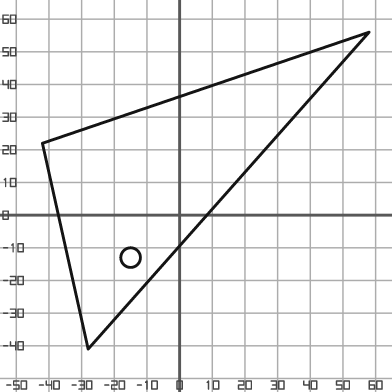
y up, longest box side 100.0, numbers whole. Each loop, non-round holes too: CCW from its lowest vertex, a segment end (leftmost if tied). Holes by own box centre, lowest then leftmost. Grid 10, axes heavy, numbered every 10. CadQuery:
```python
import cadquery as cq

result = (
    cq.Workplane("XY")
    .moveTo(-28.0, -41.0)
    .lineTo(58.0, 56.0)
    .lineTo(-42.0, 22.0)
    .close()
    .moveTo(-15.0, -13.0)
    .circle(3.0)
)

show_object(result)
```